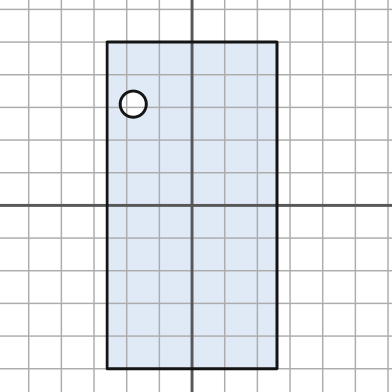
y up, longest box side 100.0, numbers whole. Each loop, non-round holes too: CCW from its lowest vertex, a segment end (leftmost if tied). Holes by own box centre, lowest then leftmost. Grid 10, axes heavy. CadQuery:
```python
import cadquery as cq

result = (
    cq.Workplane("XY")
    .moveTo(-26.0, -50.0)
    .lineTo(26.0, -50.0)
    .lineTo(26.0, 50.0)
    .lineTo(-26.0, 50.0)
    .close()
    .moveTo(-18.0, 31.0)
    .circle(4.0)
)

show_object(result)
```